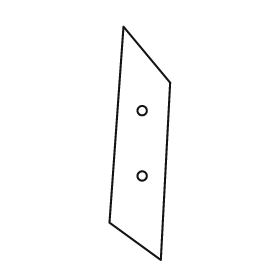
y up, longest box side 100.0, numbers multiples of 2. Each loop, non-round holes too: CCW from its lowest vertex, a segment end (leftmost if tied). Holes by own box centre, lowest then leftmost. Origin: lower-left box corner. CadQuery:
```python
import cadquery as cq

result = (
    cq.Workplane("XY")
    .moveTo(22.0, 0.0)
    .lineTo(26.0, 76.0)
    .lineTo(6.0, 100.0)
    .lineTo(0.0, 16.0)
    .close()
    .moveTo(14.0, 36.0)
    .circle(2.0)
    .moveTo(14.0, 64.0)
    .circle(2.0)
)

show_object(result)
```